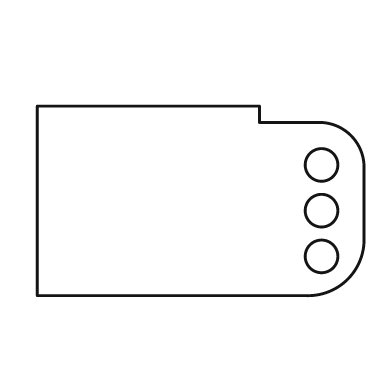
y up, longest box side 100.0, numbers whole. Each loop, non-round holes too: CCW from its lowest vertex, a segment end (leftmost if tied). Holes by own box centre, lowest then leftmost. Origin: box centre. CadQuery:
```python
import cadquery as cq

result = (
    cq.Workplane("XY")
    .moveTo(-50.0, -29.0)
    .lineTo(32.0, -29.0)
    .threePointArc((45.0, -24.0), (50.0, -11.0))
    .lineTo(50.0, 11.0)
    .threePointArc((46.0, 20.0), (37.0, 24.0))
    .lineTo(18.0, 24.0)
    .lineTo(18.0, 29.0)
    .lineTo(-50.0, 29.0)
    .close()
    .moveTo(37.0, -17.0)
    .circle(5.0)
    .moveTo(37.0, -3.0)
    .circle(5.0)
    .moveTo(37.0, 11.0)
    .circle(5.0)
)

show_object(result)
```